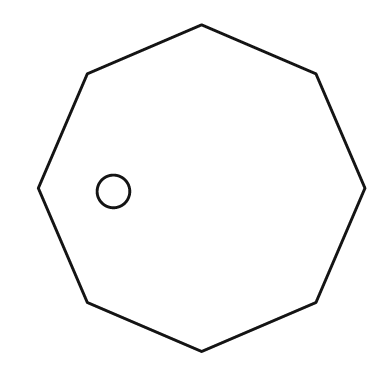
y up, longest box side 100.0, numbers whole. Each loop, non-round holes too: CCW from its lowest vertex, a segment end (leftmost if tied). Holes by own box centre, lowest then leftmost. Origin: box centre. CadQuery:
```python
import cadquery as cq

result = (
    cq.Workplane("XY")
    .moveTo(0.0, -50.0)
    .lineTo(35.0, -35.0)
    .lineTo(50.0, 0.0)
    .lineTo(35.0, 35.0)
    .lineTo(0.0, 50.0)
    .lineTo(-35.0, 35.0)
    .lineTo(-50.0, 0.0)
    .lineTo(-35.0, -35.0)
    .close()
    .moveTo(-27.0, -1.0)
    .circle(5.0)
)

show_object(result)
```